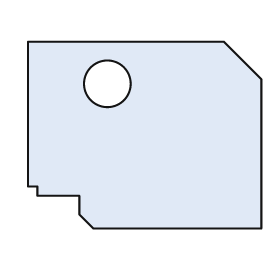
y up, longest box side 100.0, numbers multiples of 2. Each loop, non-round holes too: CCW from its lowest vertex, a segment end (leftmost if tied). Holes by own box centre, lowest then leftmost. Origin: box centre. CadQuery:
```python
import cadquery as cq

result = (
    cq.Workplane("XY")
    .moveTo(-22.0, -40.0)
    .lineTo(50.0, -40.0)
    .lineTo(50.0, 24.0)
    .lineTo(34.0, 40.0)
    .lineTo(-50.0, 40.0)
    .lineTo(-50.0, -22.0)
    .lineTo(-46.0, -22.0)
    .lineTo(-46.0, -26.0)
    .lineTo(-28.0, -26.0)
    .lineTo(-28.0, -34.0)
    .close()
    .moveTo(-16.0, 22.0)
    .circle(10.0)
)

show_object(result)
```